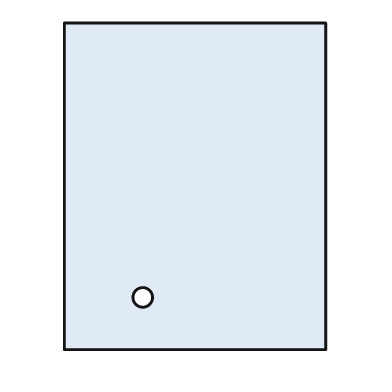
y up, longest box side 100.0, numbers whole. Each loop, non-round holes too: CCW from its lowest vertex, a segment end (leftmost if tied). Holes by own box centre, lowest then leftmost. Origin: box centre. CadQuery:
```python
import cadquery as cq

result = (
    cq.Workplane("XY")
    .moveTo(-40.0, -50.0)
    .lineTo(40.0, -50.0)
    .lineTo(40.0, 50.0)
    .lineTo(-40.0, 50.0)
    .close()
    .moveTo(-16.0, -34.0)
    .circle(3.0)
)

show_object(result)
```